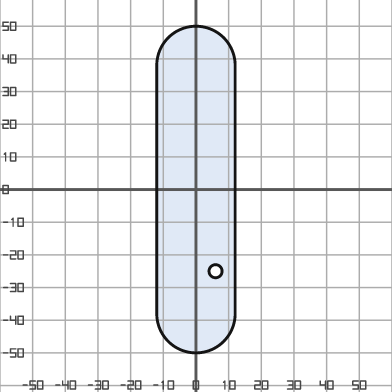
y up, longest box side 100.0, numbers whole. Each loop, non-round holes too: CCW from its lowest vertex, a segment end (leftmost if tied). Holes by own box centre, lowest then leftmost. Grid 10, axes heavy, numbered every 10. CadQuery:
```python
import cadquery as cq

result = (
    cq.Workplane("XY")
    .moveTo(-12.0, -38.0)
    .threePointArc((0.0, -50.0), (12.0, -38.0))
    .lineTo(12.0, 38.0)
    .threePointArc((0.0, 50.0), (-12.0, 38.0))
    .close()
    .moveTo(6.0, -25.0)
    .circle(2.0)
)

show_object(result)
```